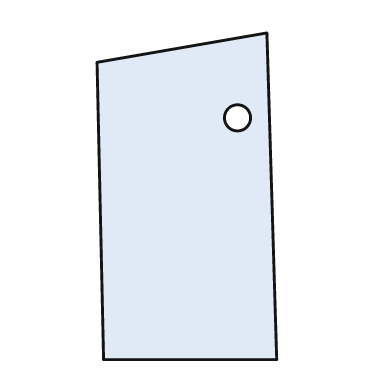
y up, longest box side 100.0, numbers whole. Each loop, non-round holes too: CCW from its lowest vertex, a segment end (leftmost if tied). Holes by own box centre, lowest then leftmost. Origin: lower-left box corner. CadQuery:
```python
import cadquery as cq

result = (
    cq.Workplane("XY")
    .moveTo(2.0, 0.0)
    .lineTo(55.0, 0.0)
    .lineTo(52.0, 100.0)
    .lineTo(0.0, 91.0)
    .close()
    .moveTo(43.0, 74.0)
    .circle(4.0)
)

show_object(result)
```